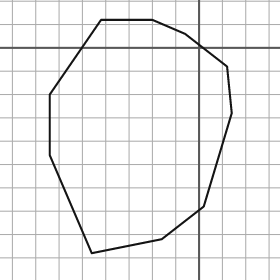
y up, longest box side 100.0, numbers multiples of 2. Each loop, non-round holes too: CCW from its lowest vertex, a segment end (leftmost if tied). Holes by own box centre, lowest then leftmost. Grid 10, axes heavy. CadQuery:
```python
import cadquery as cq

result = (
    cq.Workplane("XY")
    .moveTo(-46.0, -88.0)
    .lineTo(-16.0, -82.0)
    .lineTo(2.0, -68.0)
    .lineTo(14.0, -28.0)
    .lineTo(12.0, -8.0)
    .lineTo(-6.0, 6.0)
    .lineTo(-20.0, 12.0)
    .lineTo(-42.0, 12.0)
    .lineTo(-64.0, -20.0)
    .lineTo(-64.0, -46.0)
    .close()
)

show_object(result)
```